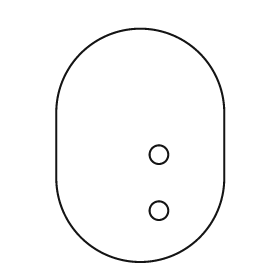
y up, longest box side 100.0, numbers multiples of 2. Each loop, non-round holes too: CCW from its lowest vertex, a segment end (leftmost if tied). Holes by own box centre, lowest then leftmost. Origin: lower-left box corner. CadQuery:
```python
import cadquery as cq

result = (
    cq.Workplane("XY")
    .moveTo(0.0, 36.0)
    .threePointArc((36.0, 0.0), (72.0, 36.0))
    .lineTo(72.0, 64.0)
    .threePointArc((36.0, 100.0), (0.0, 64.0))
    .close()
    .moveTo(44.0, 22.0)
    .circle(4.0)
    .moveTo(44.0, 46.0)
    .circle(4.0)
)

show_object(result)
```